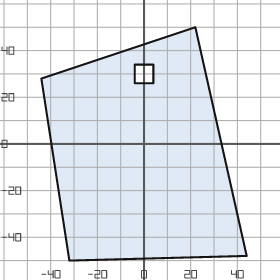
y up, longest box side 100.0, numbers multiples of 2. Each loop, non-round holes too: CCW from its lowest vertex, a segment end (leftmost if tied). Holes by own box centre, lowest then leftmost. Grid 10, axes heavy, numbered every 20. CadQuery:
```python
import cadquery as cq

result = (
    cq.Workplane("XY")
    .moveTo(-32.0, -50.0)
    .lineTo(44.0, -48.0)
    .lineTo(22.0, 50.0)
    .lineTo(-44.0, 28.0)
    .close()
    .moveTo(-4.0, 26.0)
    .lineTo(4.0, 26.0)
    .lineTo(4.0, 34.0)
    .lineTo(-4.0, 34.0)
    .close()
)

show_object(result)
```